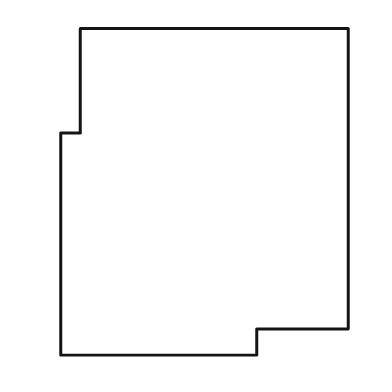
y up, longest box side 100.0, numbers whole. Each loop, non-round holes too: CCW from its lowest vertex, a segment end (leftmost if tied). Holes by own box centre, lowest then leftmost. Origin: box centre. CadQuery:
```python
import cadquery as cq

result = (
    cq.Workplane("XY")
    .moveTo(-44.0, -50.0)
    .lineTo(16.0, -50.0)
    .lineTo(16.0, -42.0)
    .lineTo(44.0, -42.0)
    .lineTo(44.0, 50.0)
    .lineTo(-38.0, 50.0)
    .lineTo(-38.0, 18.0)
    .lineTo(-44.0, 18.0)
    .close()
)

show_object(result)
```